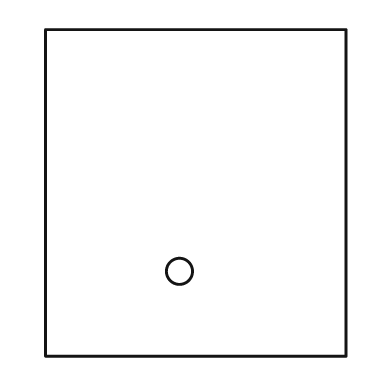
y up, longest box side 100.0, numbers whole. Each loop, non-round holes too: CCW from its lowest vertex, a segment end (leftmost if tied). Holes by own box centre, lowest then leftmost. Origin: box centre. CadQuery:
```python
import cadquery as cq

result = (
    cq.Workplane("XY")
    .moveTo(-46.0, -50.0)
    .lineTo(46.0, -50.0)
    .lineTo(46.0, 50.0)
    .lineTo(-46.0, 50.0)
    .close()
    .moveTo(-5.0, -24.0)
    .circle(4.0)
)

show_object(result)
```